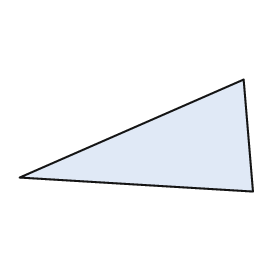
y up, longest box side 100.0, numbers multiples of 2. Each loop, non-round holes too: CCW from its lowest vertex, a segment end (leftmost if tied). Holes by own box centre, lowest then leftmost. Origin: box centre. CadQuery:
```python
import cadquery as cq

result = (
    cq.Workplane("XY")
    .moveTo(50.0, -24.0)
    .lineTo(46.0, 24.0)
    .lineTo(-50.0, -18.0)
    .close()
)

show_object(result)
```